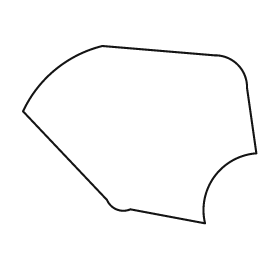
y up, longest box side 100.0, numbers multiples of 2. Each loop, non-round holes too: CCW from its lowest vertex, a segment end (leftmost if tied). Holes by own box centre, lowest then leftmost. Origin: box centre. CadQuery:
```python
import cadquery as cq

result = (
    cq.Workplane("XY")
    .moveTo(28.0, -38.0)
    .threePointArc((32.0, -18.0), (50.0, -8.0))
    .lineTo(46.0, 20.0)
    .threePointArc((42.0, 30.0), (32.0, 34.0))
    .lineTo(-16.0, 38.0)
    .threePointArc((-36.0, 28.0), (-50.0, 10.0))
    .lineTo(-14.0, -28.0)
    .threePointArc((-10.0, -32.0), (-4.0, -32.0))
    .close()
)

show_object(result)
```